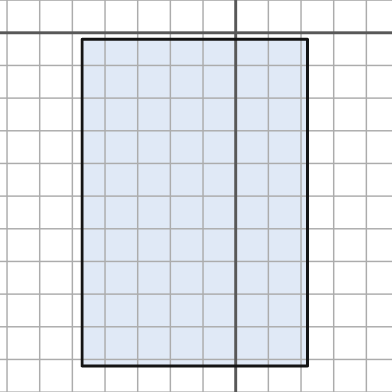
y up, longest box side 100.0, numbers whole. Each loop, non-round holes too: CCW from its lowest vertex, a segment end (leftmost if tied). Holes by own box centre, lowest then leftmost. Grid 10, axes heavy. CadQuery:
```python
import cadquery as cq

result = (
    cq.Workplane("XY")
    .moveTo(-47.0, -102.0)
    .lineTo(22.0, -102.0)
    .lineTo(22.0, -2.0)
    .lineTo(-47.0, -2.0)
    .close()
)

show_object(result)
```